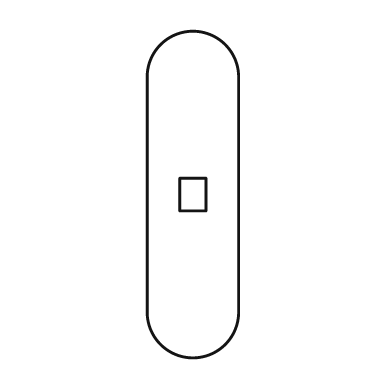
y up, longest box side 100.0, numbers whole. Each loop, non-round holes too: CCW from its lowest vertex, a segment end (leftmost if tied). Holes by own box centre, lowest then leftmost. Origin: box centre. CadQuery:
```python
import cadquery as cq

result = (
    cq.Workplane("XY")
    .moveTo(-14.0, -36.0)
    .threePointArc((0.0, -50.0), (14.0, -36.0))
    .lineTo(14.0, 36.0)
    .threePointArc((0.0, 50.0), (-14.0, 36.0))
    .close()
    .moveTo(-4.0, -5.0)
    .lineTo(4.0, -5.0)
    .lineTo(4.0, 5.0)
    .lineTo(-4.0, 5.0)
    .close()
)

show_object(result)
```